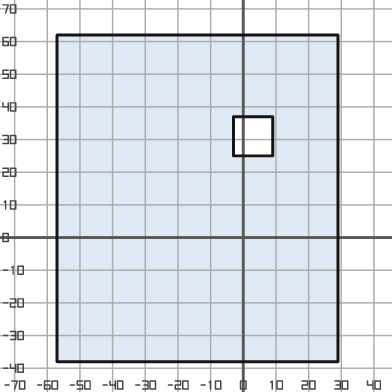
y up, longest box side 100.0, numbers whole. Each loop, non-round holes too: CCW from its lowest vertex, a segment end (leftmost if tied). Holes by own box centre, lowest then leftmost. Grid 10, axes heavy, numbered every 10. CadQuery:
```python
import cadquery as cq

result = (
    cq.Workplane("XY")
    .moveTo(-57.0, -38.0)
    .lineTo(29.0, -38.0)
    .lineTo(29.0, 62.0)
    .lineTo(-57.0, 62.0)
    .close()
    .moveTo(-3.0, 25.0)
    .lineTo(9.0, 25.0)
    .lineTo(9.0, 37.0)
    .lineTo(-3.0, 37.0)
    .close()
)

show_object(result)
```